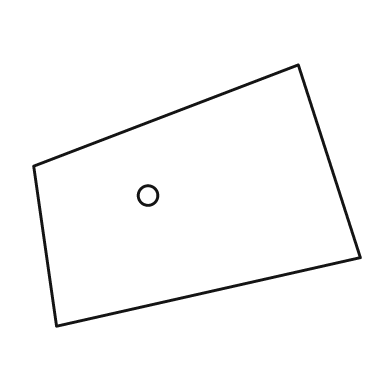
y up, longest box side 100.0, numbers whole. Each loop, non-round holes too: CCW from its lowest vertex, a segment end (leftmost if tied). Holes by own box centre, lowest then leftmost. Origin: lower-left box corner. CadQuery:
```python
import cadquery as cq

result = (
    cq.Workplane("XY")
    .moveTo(7.0, 0.0)
    .lineTo(100.0, 21.0)
    .lineTo(81.0, 80.0)
    .lineTo(0.0, 49.0)
    .close()
    .moveTo(35.0, 40.0)
    .circle(3.0)
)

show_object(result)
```